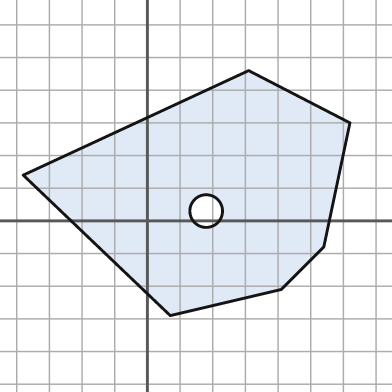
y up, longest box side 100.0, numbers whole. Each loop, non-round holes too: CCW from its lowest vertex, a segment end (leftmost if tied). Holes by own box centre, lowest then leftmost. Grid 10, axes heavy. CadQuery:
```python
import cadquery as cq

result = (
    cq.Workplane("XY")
    .moveTo(7.0, -29.0)
    .lineTo(41.0, -21.0)
    .lineTo(54.0, -8.0)
    .lineTo(62.0, 30.0)
    .lineTo(31.0, 46.0)
    .lineTo(-38.0, 14.0)
    .close()
    .moveTo(18.0, 3.0)
    .circle(5.0)
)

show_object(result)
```